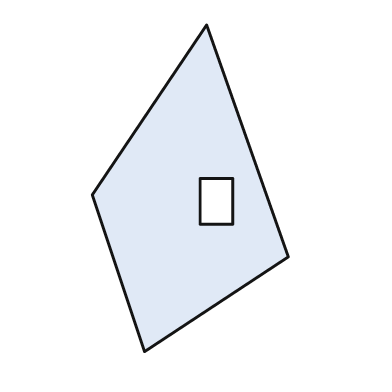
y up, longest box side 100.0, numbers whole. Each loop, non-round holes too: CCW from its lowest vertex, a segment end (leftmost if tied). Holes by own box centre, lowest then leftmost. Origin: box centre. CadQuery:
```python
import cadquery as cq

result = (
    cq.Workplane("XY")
    .moveTo(-14.0, -50.0)
    .lineTo(30.0, -21.0)
    .lineTo(5.0, 50.0)
    .lineTo(-30.0, -2.0)
    .close()
    .moveTo(3.0, -11.0)
    .lineTo(13.0, -11.0)
    .lineTo(13.0, 3.0)
    .lineTo(3.0, 3.0)
    .close()
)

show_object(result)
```